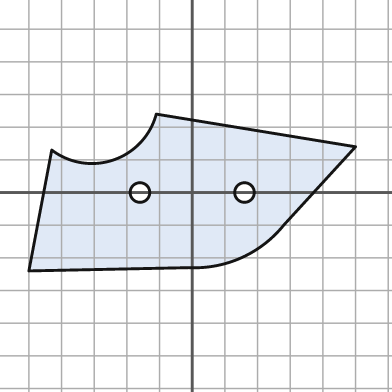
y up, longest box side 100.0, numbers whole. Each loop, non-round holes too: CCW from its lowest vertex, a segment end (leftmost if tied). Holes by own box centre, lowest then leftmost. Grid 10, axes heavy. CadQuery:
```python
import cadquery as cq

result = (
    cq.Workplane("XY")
    .moveTo(-50.0, -24.0)
    .lineTo(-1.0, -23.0)
    .threePointArc((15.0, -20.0), (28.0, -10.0))
    .lineTo(50.0, 14.0)
    .lineTo(-11.0, 24.0)
    .threePointArc((-24.0, 10.0), (-43.0, 13.0))
    .close()
    .moveTo(-16.0, 0.0)
    .circle(3.0)
    .moveTo(16.0, 0.0)
    .circle(3.0)
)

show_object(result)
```